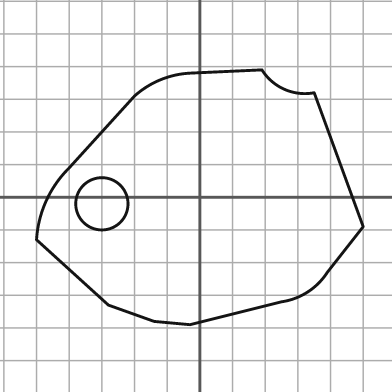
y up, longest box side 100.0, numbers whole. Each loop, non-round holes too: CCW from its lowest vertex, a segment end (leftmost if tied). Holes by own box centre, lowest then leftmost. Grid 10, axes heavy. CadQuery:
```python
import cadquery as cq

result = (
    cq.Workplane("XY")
    .moveTo(-3.0, -39.0)
    .lineTo(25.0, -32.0)
    .threePointArc((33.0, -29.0), (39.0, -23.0))
    .lineTo(50.0, -9.0)
    .lineTo(35.0, 32.0)
    .threePointArc((26.0, 33.0), (19.0, 39.0))
    .lineTo(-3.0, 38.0)
    .threePointArc((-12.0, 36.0), (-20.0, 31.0))
    .lineTo(-40.0, 9.0)
    .threePointArc((-47.0, -1.0), (-50.0, -13.0))
    .lineTo(-28.0, -33.0)
    .lineTo(-14.0, -38.0)
    .close()
    .moveTo(-30.0, -2.0)
    .circle(8.0)
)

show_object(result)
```